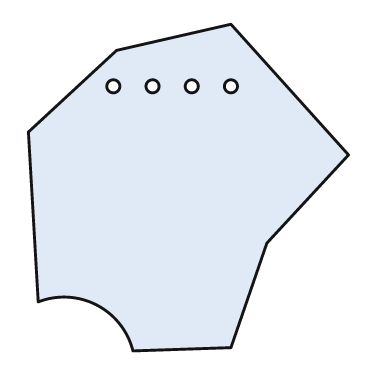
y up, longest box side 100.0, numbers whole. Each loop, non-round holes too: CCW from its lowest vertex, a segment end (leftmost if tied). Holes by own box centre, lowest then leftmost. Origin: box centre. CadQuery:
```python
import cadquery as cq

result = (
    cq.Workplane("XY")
    .moveTo(-17.0, -50.0)
    .lineTo(13.0, -49.0)
    .lineTo(24.0, -17.0)
    .lineTo(49.0, 10.0)
    .lineTo(13.0, 50.0)
    .lineTo(-22.0, 42.0)
    .lineTo(-49.0, 17.0)
    .lineTo(-46.0, -35.0)
    .threePointArc((-28.0, -36.0), (-17.0, -50.0))
    .close()
    .moveTo(-23.0, 31.0)
    .circle(2.0)
    .moveTo(-11.0, 31.0)
    .circle(2.0)
    .moveTo(1.0, 31.0)
    .circle(2.0)
    .moveTo(13.0, 31.0)
    .circle(2.0)
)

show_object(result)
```